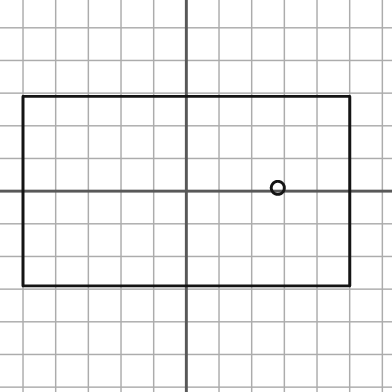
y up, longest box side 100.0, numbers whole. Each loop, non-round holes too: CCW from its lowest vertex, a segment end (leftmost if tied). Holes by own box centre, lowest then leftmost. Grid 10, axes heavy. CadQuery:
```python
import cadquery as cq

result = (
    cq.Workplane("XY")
    .moveTo(-50.0, -29.0)
    .lineTo(50.0, -29.0)
    .lineTo(50.0, 29.0)
    .lineTo(-50.0, 29.0)
    .close()
    .moveTo(28.0, 1.0)
    .circle(2.0)
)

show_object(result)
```